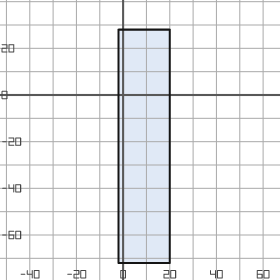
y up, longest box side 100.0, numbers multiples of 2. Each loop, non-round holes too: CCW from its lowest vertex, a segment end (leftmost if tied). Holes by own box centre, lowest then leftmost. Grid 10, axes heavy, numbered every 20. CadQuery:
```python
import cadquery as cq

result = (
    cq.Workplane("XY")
    .moveTo(-2.0, -72.0)
    .lineTo(20.0, -72.0)
    .lineTo(20.0, 28.0)
    .lineTo(-2.0, 28.0)
    .close()
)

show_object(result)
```